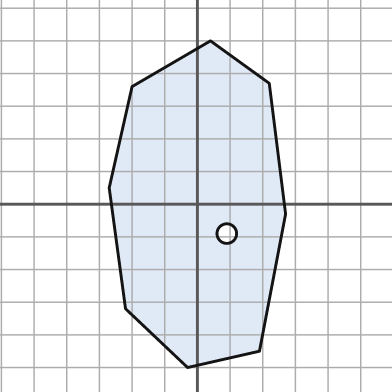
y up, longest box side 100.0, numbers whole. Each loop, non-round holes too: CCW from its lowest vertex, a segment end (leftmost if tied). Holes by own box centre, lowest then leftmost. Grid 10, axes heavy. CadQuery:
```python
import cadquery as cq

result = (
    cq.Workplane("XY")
    .moveTo(-3.0, -50.0)
    .lineTo(19.0, -45.0)
    .lineTo(27.0, -3.0)
    .lineTo(22.0, 37.0)
    .lineTo(4.0, 50.0)
    .lineTo(-20.0, 36.0)
    .lineTo(-27.0, 5.0)
    .lineTo(-22.0, -32.0)
    .close()
    .moveTo(9.0, -9.0)
    .circle(3.0)
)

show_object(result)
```